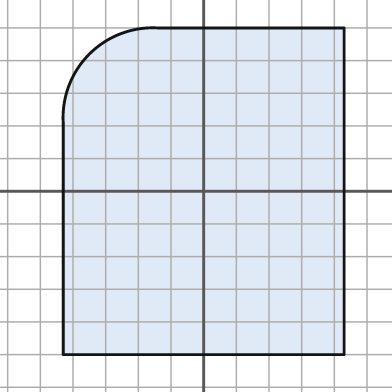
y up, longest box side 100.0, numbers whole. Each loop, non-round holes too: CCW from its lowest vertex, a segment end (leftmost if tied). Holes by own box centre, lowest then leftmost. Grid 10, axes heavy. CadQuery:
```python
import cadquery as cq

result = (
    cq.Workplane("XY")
    .moveTo(-43.0, -50.0)
    .lineTo(43.0, -50.0)
    .lineTo(43.0, 50.0)
    .lineTo(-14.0, 50.0)
    .threePointArc((-35.0, 42.0), (-43.0, 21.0))
    .close()
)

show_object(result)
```